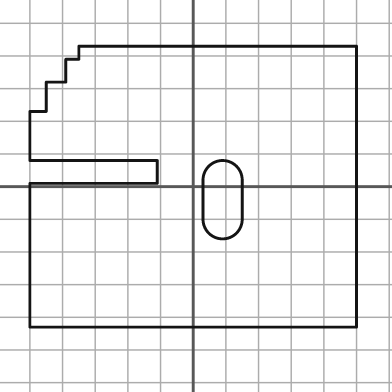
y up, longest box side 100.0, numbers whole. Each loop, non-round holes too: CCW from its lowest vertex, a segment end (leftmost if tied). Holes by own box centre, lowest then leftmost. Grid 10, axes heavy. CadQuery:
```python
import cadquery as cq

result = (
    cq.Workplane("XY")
    .moveTo(-50.0, -43.0)
    .lineTo(50.0, -43.0)
    .lineTo(50.0, 43.0)
    .lineTo(-35.0, 43.0)
    .lineTo(-35.0, 39.0)
    .lineTo(-39.0, 39.0)
    .lineTo(-39.0, 32.0)
    .lineTo(-45.0, 32.0)
    .lineTo(-45.0, 23.0)
    .lineTo(-50.0, 23.0)
    .lineTo(-50.0, 8.0)
    .lineTo(-11.0, 8.0)
    .lineTo(-11.0, 1.0)
    .lineTo(-50.0, 1.0)
    .close()
    .moveTo(3.0, -10.0)
    .threePointArc((9.0, -16.0), (15.0, -10.0))
    .lineTo(15.0, 2.0)
    .threePointArc((9.0, 8.0), (3.0, 2.0))
    .close()
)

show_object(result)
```